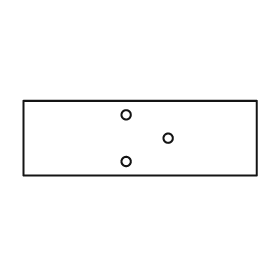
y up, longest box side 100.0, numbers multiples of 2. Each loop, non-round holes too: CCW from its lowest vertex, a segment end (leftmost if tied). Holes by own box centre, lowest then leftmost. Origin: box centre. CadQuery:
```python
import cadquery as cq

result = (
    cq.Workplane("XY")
    .moveTo(-50.0, -16.0)
    .lineTo(50.0, -16.0)
    .lineTo(50.0, 16.0)
    .lineTo(-50.0, 16.0)
    .close()
    .moveTo(-6.0, -10.0)
    .circle(2.0)
    .moveTo(12.0, 0.0)
    .circle(2.0)
    .moveTo(-6.0, 10.0)
    .circle(2.0)
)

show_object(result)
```